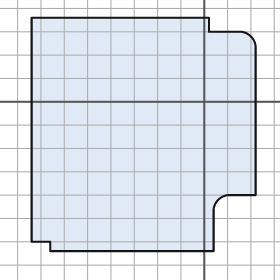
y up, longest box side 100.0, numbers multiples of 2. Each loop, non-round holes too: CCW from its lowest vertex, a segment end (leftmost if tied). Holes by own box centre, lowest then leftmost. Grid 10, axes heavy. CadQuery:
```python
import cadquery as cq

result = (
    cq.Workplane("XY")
    .moveTo(-66.0, -64.0)
    .lineTo(4.0, -64.0)
    .lineTo(4.0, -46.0)
    .threePointArc((6.0, -42.0), (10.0, -40.0))
    .lineTo(22.0, -40.0)
    .lineTo(22.0, 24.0)
    .threePointArc((20.0, 28.0), (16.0, 30.0))
    .lineTo(2.0, 30.0)
    .lineTo(2.0, 36.0)
    .lineTo(-74.0, 36.0)
    .lineTo(-74.0, -60.0)
    .lineTo(-66.0, -60.0)
    .close()
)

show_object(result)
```